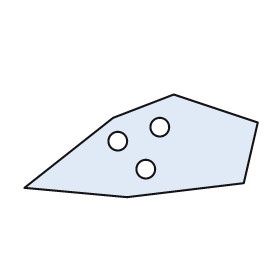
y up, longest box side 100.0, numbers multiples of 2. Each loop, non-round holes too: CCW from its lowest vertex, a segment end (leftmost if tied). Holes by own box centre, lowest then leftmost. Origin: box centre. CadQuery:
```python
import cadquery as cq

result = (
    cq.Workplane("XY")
    .moveTo(-6.0, -22.0)
    .lineTo(44.0, -16.0)
    .lineTo(50.0, 10.0)
    .lineTo(14.0, 22.0)
    .lineTo(-12.0, 12.0)
    .lineTo(-50.0, -18.0)
    .close()
    .moveTo(2.0, -10.0)
    .circle(4.0)
    .moveTo(-10.0, 2.0)
    .circle(4.0)
    .moveTo(8.0, 8.0)
    .circle(4.0)
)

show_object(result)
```